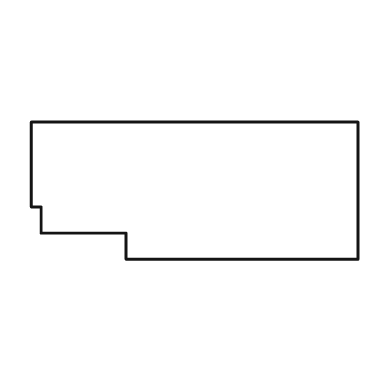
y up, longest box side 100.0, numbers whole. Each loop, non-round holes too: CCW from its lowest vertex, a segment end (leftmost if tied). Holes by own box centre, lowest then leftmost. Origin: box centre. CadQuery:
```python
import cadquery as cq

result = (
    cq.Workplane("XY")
    .moveTo(-21.0, -21.0)
    .lineTo(50.0, -21.0)
    .lineTo(50.0, 21.0)
    .lineTo(-50.0, 21.0)
    .lineTo(-50.0, -5.0)
    .lineTo(-47.0, -5.0)
    .lineTo(-47.0, -13.0)
    .lineTo(-21.0, -13.0)
    .close()
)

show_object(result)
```